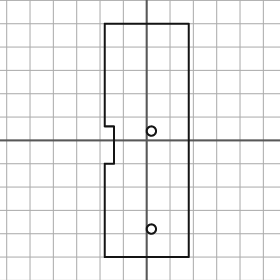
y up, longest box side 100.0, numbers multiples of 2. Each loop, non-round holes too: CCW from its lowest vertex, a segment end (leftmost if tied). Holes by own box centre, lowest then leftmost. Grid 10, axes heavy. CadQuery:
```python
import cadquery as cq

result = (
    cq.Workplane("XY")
    .moveTo(-18.0, -50.0)
    .lineTo(18.0, -50.0)
    .lineTo(18.0, 50.0)
    .lineTo(-18.0, 50.0)
    .lineTo(-18.0, 6.0)
    .lineTo(-14.0, 6.0)
    .lineTo(-14.0, -10.0)
    .lineTo(-18.0, -10.0)
    .close()
    .moveTo(2.0, -38.0)
    .circle(2.0)
    .moveTo(2.0, 4.0)
    .circle(2.0)
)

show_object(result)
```